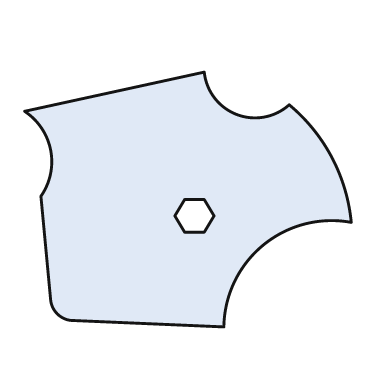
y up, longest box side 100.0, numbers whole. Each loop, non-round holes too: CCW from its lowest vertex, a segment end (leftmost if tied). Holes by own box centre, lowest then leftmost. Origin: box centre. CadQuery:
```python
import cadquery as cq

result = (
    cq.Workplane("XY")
    .moveTo(11.0, -39.0)
    .threePointArc((23.0, -14.0), (50.0, -7.0))
    .threePointArc((44.0, 13.0), (31.0, 29.0))
    .threePointArc((15.0, 26.0), (5.0, 39.0))
    .lineTo(-50.0, 27.0)
    .threePointArc((-42.0, 15.0), (-45.0, 1.0))
    .lineTo(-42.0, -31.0)
    .threePointArc((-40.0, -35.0), (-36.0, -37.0))
    .close()
    .moveTo(-1.0, -10.0)
    .lineTo(5.0, -10.0)
    .lineTo(8.0, -5.0)
    .lineTo(5.0, 0.0)
    .lineTo(-1.0, 0.0)
    .lineTo(-4.0, -5.0)
    .close()
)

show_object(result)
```